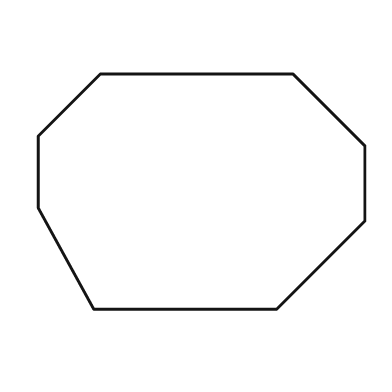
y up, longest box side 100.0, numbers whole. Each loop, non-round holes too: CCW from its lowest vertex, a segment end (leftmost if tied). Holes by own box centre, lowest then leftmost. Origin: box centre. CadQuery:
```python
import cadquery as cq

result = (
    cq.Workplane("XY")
    .moveTo(-33.0, -36.0)
    .lineTo(23.0, -36.0)
    .lineTo(50.0, -9.0)
    .lineTo(50.0, 14.0)
    .lineTo(28.0, 36.0)
    .lineTo(-31.0, 36.0)
    .lineTo(-50.0, 17.0)
    .lineTo(-50.0, -5.0)
    .close()
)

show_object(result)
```